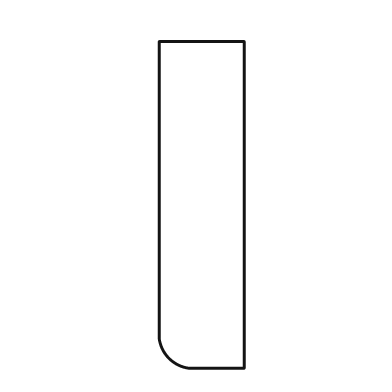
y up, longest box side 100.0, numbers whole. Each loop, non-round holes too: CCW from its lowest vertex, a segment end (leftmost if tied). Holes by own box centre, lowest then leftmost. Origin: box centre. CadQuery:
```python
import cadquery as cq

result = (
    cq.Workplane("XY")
    .moveTo(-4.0, -50.0)
    .lineTo(13.0, -50.0)
    .lineTo(13.0, 50.0)
    .lineTo(-13.0, 50.0)
    .lineTo(-13.0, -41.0)
    .threePointArc((-10.0, -47.0), (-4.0, -50.0))
    .close()
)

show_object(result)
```